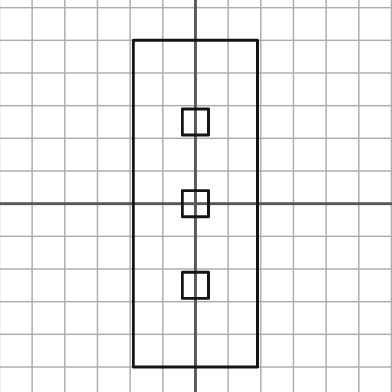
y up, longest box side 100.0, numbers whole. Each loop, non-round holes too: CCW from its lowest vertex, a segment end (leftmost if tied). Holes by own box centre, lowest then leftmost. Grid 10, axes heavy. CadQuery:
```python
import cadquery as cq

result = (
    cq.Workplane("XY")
    .moveTo(-19.0, -50.0)
    .lineTo(19.0, -50.0)
    .lineTo(19.0, 50.0)
    .lineTo(-19.0, 50.0)
    .close()
    .moveTo(-4.0, -29.0)
    .lineTo(4.0, -29.0)
    .lineTo(4.0, -21.0)
    .lineTo(-4.0, -21.0)
    .close()
    .moveTo(-4.0, -4.0)
    .lineTo(4.0, -4.0)
    .lineTo(4.0, 4.0)
    .lineTo(-4.0, 4.0)
    .close()
    .moveTo(-4.0, 21.0)
    .lineTo(4.0, 21.0)
    .lineTo(4.0, 29.0)
    .lineTo(-4.0, 29.0)
    .close()
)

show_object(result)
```